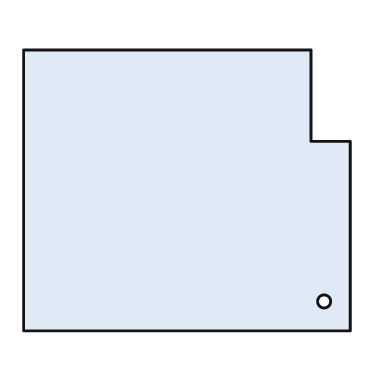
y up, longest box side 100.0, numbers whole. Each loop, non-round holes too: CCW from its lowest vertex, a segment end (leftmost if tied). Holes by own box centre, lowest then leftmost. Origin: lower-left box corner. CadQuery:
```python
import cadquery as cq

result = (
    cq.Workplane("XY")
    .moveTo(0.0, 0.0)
    .lineTo(100.0, 0.0)
    .lineTo(100.0, 58.0)
    .lineTo(88.0, 58.0)
    .lineTo(88.0, 86.0)
    .lineTo(0.0, 86.0)
    .close()
    .moveTo(92.0, 9.0)
    .circle(2.0)
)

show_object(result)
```